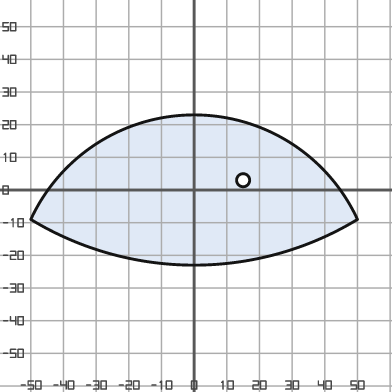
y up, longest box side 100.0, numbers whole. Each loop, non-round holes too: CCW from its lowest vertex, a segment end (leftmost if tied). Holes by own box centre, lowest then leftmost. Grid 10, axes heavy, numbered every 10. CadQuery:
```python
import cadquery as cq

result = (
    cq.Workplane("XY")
    .moveTo(-50.0, -9.0)
    .threePointArc((0.0, -23.0), (50.0, -9.0))
    .threePointArc((0.0, 23.0), (-50.0, -9.0))
    .close()
    .moveTo(15.0, 3.0)
    .circle(2.0)
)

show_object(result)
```